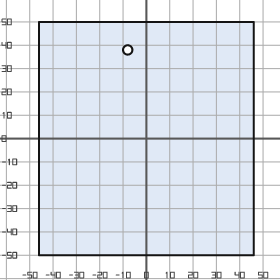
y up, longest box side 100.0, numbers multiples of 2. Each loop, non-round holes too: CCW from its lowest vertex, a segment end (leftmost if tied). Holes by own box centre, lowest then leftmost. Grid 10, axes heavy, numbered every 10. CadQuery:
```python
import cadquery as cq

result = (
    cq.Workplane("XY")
    .moveTo(-46.0, -50.0)
    .lineTo(46.0, -50.0)
    .lineTo(46.0, 50.0)
    .lineTo(-46.0, 50.0)
    .close()
    .moveTo(-8.0, 38.0)
    .circle(2.0)
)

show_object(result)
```